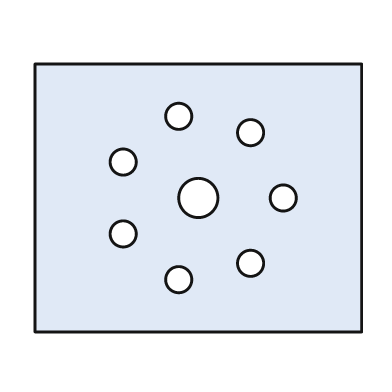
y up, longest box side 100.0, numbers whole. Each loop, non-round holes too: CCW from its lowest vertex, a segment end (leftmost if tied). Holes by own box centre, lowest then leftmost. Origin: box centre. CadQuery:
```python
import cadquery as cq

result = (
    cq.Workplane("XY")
    .moveTo(-50.0, -41.0)
    .lineTo(50.0, -41.0)
    .lineTo(50.0, 41.0)
    .lineTo(-50.0, 41.0)
    .close()
    .moveTo(-6.0, -25.0)
    .circle(4.0)
    .moveTo(16.0, -20.0)
    .circle(4.0)
    .moveTo(-23.0, -11.0)
    .circle(4.0)
    .moveTo(0.0, 0.0)
    .circle(6.0)
    .moveTo(26.0, 0.0)
    .circle(4.0)
    .moveTo(-23.0, 11.0)
    .circle(4.0)
    .moveTo(16.0, 20.0)
    .circle(4.0)
    .moveTo(-6.0, 25.0)
    .circle(4.0)
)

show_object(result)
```